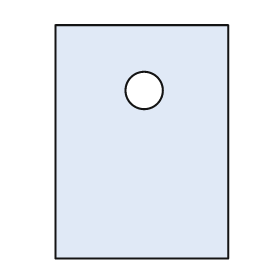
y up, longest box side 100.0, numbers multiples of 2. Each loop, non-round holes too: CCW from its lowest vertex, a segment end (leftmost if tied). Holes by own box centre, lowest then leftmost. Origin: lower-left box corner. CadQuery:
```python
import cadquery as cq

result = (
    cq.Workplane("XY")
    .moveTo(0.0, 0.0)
    .lineTo(74.0, 0.0)
    .lineTo(74.0, 100.0)
    .lineTo(0.0, 100.0)
    .close()
    .moveTo(38.0, 72.0)
    .circle(8.0)
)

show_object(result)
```